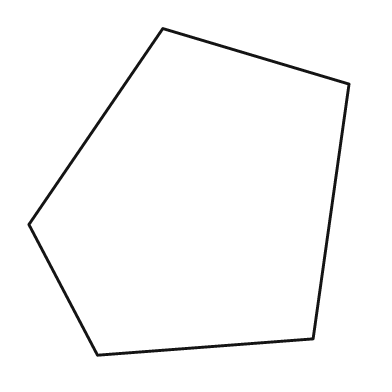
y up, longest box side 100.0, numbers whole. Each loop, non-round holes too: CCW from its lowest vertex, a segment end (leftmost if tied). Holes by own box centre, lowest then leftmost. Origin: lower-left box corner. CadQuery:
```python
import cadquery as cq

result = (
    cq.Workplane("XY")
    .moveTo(21.0, 0.0)
    .lineTo(87.0, 5.0)
    .lineTo(98.0, 83.0)
    .lineTo(41.0, 100.0)
    .lineTo(0.0, 40.0)
    .close()
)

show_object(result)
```